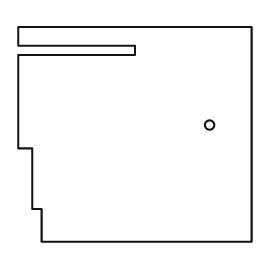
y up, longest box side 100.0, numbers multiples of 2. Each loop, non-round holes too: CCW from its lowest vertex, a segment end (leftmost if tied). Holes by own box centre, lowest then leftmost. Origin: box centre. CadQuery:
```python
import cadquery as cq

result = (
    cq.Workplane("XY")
    .moveTo(-40.0, -46.0)
    .lineTo(50.0, -46.0)
    .lineTo(50.0, 46.0)
    .lineTo(-50.0, 46.0)
    .lineTo(-50.0, 38.0)
    .lineTo(0.0, 38.0)
    .lineTo(0.0, 34.0)
    .lineTo(-50.0, 34.0)
    .lineTo(-50.0, -6.0)
    .lineTo(-44.0, -6.0)
    .lineTo(-44.0, -32.0)
    .lineTo(-40.0, -32.0)
    .close()
    .moveTo(32.0, 4.0)
    .circle(2.0)
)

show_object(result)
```